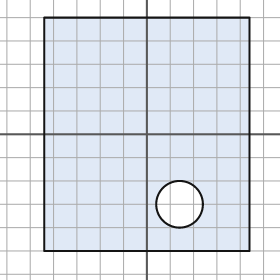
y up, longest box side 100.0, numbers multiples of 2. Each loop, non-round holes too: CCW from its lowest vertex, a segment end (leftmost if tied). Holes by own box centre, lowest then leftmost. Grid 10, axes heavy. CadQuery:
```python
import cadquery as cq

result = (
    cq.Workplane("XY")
    .moveTo(-44.0, -50.0)
    .lineTo(44.0, -50.0)
    .lineTo(44.0, 50.0)
    .lineTo(-44.0, 50.0)
    .close()
    .moveTo(14.0, -30.0)
    .circle(10.0)
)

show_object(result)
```